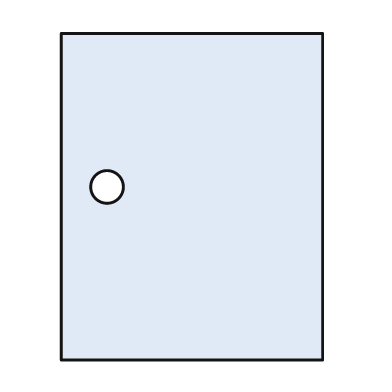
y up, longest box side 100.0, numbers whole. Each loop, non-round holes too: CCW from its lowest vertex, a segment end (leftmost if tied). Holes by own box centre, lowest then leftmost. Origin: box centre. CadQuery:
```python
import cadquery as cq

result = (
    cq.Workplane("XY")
    .moveTo(-40.0, -50.0)
    .lineTo(40.0, -50.0)
    .lineTo(40.0, 50.0)
    .lineTo(-40.0, 50.0)
    .close()
    .moveTo(-26.0, 3.0)
    .circle(5.0)
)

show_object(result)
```